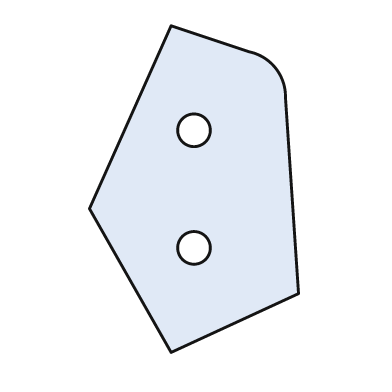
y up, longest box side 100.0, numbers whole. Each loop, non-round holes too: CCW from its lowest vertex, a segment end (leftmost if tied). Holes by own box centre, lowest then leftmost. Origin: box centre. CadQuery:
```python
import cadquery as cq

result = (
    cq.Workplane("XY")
    .moveTo(-7.0, -50.0)
    .lineTo(32.0, -32.0)
    .lineTo(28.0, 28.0)
    .threePointArc((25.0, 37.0), (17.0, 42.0))
    .lineTo(-7.0, 50.0)
    .lineTo(-32.0, -6.0)
    .close()
    .moveTo(0.0, -18.0)
    .circle(5.0)
    .moveTo(0.0, 18.0)
    .circle(5.0)
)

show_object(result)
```